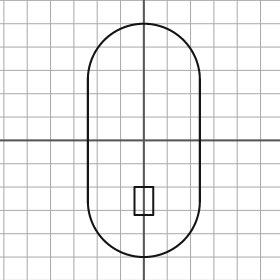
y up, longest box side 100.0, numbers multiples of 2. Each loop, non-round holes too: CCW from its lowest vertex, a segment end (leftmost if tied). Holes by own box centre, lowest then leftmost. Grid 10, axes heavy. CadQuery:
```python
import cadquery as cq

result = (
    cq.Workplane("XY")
    .moveTo(-24.0, -26.0)
    .threePointArc((0.0, -50.0), (24.0, -26.0))
    .lineTo(24.0, 26.0)
    .threePointArc((0.0, 50.0), (-24.0, 26.0))
    .close()
    .moveTo(-4.0, -32.0)
    .lineTo(4.0, -32.0)
    .lineTo(4.0, -20.0)
    .lineTo(-4.0, -20.0)
    .close()
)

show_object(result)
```